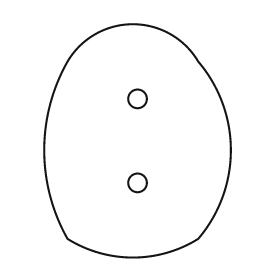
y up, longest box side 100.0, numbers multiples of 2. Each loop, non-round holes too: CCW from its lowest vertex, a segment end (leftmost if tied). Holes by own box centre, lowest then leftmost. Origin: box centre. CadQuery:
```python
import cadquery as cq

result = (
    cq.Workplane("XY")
    .moveTo(-30.0, -42.0)
    .threePointArc((-2.0, -50.0), (26.0, -42.0))
    .threePointArc((40.0, -4.0), (26.0, 34.0))
    .threePointArc((-2.0, 50.0), (-30.0, 34.0))
    .threePointArc((-40.0, -4.0), (-30.0, -42.0))
    .close()
    .moveTo(0.0, -18.0)
    .circle(4.0)
    .moveTo(0.0, 18.0)
    .circle(4.0)
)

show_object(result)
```